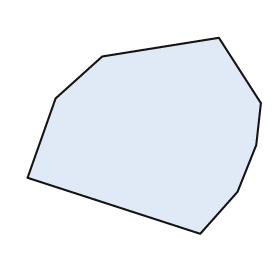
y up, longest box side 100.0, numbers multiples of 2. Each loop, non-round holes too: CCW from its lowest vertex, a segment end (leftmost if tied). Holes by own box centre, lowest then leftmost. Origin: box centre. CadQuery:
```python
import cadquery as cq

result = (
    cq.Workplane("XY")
    .moveTo(24.0, -42.0)
    .lineTo(40.0, -24.0)
    .lineTo(48.0, -4.0)
    .lineTo(50.0, 14.0)
    .lineTo(32.0, 42.0)
    .lineTo(-18.0, 34.0)
    .lineTo(-38.0, 16.0)
    .lineTo(-50.0, -18.0)
    .close()
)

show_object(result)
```